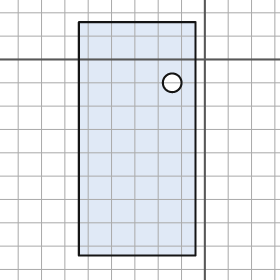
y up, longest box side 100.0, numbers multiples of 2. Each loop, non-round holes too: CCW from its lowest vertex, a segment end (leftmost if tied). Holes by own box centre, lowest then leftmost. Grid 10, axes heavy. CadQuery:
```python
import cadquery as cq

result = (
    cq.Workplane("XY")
    .moveTo(-54.0, -84.0)
    .lineTo(-4.0, -84.0)
    .lineTo(-4.0, 16.0)
    .lineTo(-54.0, 16.0)
    .close()
    .moveTo(-14.0, -10.0)
    .circle(4.0)
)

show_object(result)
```